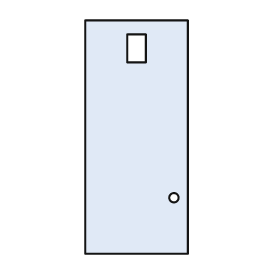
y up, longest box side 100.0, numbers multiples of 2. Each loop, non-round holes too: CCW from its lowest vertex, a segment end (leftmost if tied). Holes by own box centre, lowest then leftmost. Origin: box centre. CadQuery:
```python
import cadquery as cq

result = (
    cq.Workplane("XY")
    .moveTo(-22.0, -50.0)
    .lineTo(22.0, -50.0)
    .lineTo(22.0, 50.0)
    .lineTo(-22.0, 50.0)
    .close()
    .moveTo(16.0, -26.0)
    .circle(2.0)
    .moveTo(-4.0, 32.0)
    .lineTo(4.0, 32.0)
    .lineTo(4.0, 44.0)
    .lineTo(-4.0, 44.0)
    .close()
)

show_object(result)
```